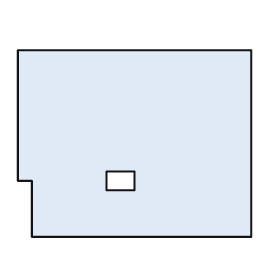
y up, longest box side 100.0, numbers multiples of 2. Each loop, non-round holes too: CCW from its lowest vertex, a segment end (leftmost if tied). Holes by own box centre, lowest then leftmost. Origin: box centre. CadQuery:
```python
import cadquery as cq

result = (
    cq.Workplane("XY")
    .moveTo(-44.0, -40.0)
    .lineTo(50.0, -40.0)
    .lineTo(50.0, 40.0)
    .lineTo(-50.0, 40.0)
    .lineTo(-50.0, -16.0)
    .lineTo(-44.0, -16.0)
    .close()
    .moveTo(-12.0, -20.0)
    .lineTo(0.0, -20.0)
    .lineTo(0.0, -12.0)
    .lineTo(-12.0, -12.0)
    .close()
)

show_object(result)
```